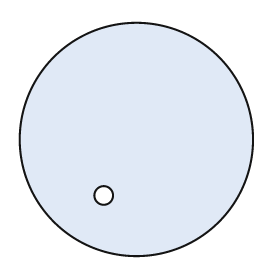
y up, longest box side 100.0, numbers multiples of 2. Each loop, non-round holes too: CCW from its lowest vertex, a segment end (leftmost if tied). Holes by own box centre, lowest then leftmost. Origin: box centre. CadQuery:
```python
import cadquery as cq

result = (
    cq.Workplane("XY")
    .moveTo(0.0, 0.0)
    .circle(50.0)
    .moveTo(-14.0, -24.0)
    .circle(4.0)
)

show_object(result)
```